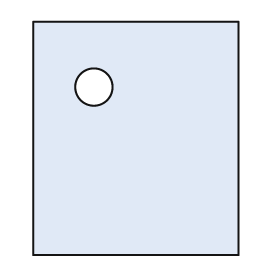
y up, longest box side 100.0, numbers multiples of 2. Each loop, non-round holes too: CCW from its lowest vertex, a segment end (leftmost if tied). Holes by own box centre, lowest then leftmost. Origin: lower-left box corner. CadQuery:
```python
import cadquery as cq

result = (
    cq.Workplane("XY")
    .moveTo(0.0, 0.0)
    .lineTo(88.0, 0.0)
    .lineTo(88.0, 100.0)
    .lineTo(0.0, 100.0)
    .close()
    .moveTo(26.0, 72.0)
    .circle(8.0)
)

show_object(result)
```